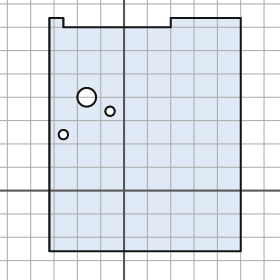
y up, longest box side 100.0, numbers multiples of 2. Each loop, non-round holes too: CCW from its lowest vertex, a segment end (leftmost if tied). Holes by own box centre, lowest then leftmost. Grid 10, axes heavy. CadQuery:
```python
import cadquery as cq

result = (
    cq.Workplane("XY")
    .moveTo(-32.0, -26.0)
    .lineTo(50.0, -26.0)
    .lineTo(50.0, 74.0)
    .lineTo(20.0, 74.0)
    .lineTo(20.0, 70.0)
    .lineTo(-26.0, 70.0)
    .lineTo(-26.0, 74.0)
    .lineTo(-32.0, 74.0)
    .close()
    .moveTo(-26.0, 24.0)
    .circle(2.0)
    .moveTo(-6.0, 34.0)
    .circle(2.0)
    .moveTo(-16.0, 40.0)
    .circle(4.0)
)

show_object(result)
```